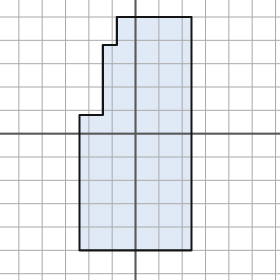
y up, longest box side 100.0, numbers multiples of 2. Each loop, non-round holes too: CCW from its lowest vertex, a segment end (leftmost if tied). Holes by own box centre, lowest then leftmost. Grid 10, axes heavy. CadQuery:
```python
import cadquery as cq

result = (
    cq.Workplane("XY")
    .moveTo(-24.0, -50.0)
    .lineTo(24.0, -50.0)
    .lineTo(24.0, 50.0)
    .lineTo(-8.0, 50.0)
    .lineTo(-8.0, 38.0)
    .lineTo(-14.0, 38.0)
    .lineTo(-14.0, 8.0)
    .lineTo(-24.0, 8.0)
    .close()
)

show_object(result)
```